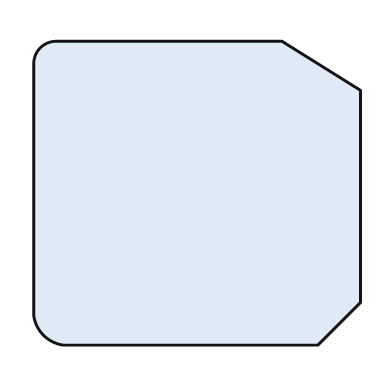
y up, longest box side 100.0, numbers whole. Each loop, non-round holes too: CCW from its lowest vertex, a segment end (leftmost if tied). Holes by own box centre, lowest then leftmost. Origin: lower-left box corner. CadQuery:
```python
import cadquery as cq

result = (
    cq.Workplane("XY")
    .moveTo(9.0, 0.0)
    .lineTo(87.0, 0.0)
    .lineTo(100.0, 13.0)
    .lineTo(100.0, 78.0)
    .lineTo(76.0, 93.0)
    .lineTo(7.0, 93.0)
    .threePointArc((2.0, 91.0), (0.0, 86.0))
    .lineTo(0.0, 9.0)
    .threePointArc((3.0, 3.0), (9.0, 0.0))
    .close()
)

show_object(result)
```